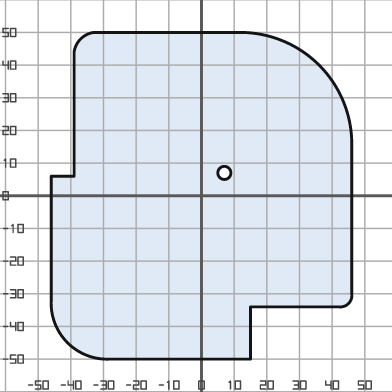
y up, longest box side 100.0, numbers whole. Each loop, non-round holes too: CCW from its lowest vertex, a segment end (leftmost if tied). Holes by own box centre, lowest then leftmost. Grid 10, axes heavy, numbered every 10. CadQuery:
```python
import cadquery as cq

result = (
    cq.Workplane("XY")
    .moveTo(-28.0, -50.0)
    .lineTo(15.0, -50.0)
    .lineTo(15.0, -34.0)
    .lineTo(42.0, -34.0)
    .threePointArc((45.0, -33.0), (46.0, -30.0))
    .lineTo(46.0, 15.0)
    .threePointArc((36.0, 40.0), (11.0, 50.0))
    .lineTo(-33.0, 50.0)
    .threePointArc((-37.0, 48.0), (-39.0, 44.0))
    .lineTo(-39.0, 6.0)
    .lineTo(-46.0, 6.0)
    .lineTo(-46.0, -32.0)
    .threePointArc((-41.0, -45.0), (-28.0, -50.0))
    .close()
    .moveTo(7.0, 7.0)
    .circle(2.0)
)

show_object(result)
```